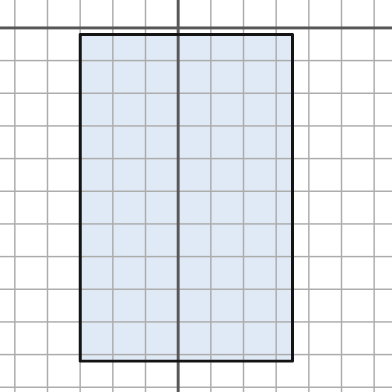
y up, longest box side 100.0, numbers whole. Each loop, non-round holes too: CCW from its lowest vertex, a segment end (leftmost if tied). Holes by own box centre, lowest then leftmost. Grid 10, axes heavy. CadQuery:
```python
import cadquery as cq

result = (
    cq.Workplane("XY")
    .moveTo(-30.0, -102.0)
    .lineTo(35.0, -102.0)
    .lineTo(35.0, -2.0)
    .lineTo(-30.0, -2.0)
    .close()
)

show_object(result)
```